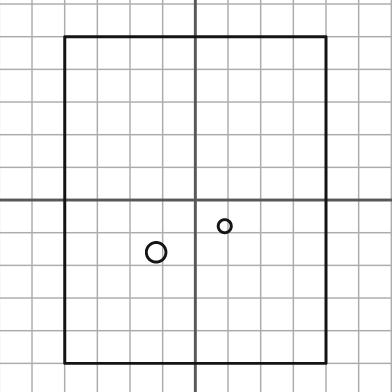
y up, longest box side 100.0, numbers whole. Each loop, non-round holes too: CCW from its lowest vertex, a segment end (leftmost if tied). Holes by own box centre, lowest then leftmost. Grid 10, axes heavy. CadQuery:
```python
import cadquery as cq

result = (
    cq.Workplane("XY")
    .moveTo(-40.0, -50.0)
    .lineTo(40.0, -50.0)
    .lineTo(40.0, 50.0)
    .lineTo(-40.0, 50.0)
    .close()
    .moveTo(-12.0, -16.0)
    .circle(3.0)
    .moveTo(9.0, -8.0)
    .circle(2.0)
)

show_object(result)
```